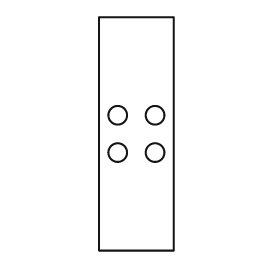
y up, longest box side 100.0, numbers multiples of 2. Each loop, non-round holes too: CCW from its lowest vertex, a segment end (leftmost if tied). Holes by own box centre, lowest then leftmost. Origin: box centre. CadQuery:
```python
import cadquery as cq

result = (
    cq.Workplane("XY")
    .moveTo(-16.0, -50.0)
    .lineTo(16.0, -50.0)
    .lineTo(16.0, 50.0)
    .lineTo(-16.0, 50.0)
    .close()
    .moveTo(-8.0, -8.0)
    .circle(4.0)
    .moveTo(8.0, -8.0)
    .circle(4.0)
    .moveTo(-8.0, 8.0)
    .circle(4.0)
    .moveTo(8.0, 8.0)
    .circle(4.0)
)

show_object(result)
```